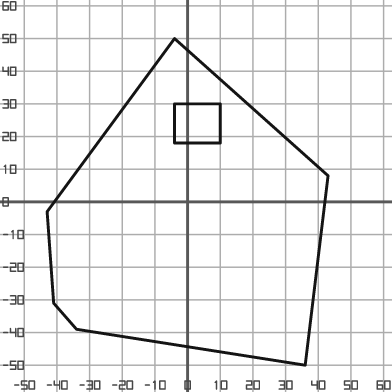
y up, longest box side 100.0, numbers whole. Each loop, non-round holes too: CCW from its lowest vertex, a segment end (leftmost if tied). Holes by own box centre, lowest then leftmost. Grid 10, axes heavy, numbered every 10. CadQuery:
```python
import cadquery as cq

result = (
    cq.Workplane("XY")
    .moveTo(36.0, -50.0)
    .lineTo(43.0, 8.0)
    .lineTo(-4.0, 50.0)
    .lineTo(-43.0, -3.0)
    .lineTo(-41.0, -31.0)
    .lineTo(-34.0, -39.0)
    .close()
    .moveTo(-4.0, 18.0)
    .lineTo(10.0, 18.0)
    .lineTo(10.0, 30.0)
    .lineTo(-4.0, 30.0)
    .close()
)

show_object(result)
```